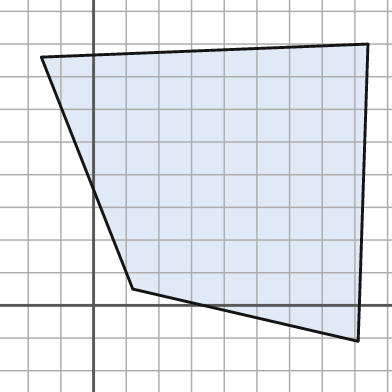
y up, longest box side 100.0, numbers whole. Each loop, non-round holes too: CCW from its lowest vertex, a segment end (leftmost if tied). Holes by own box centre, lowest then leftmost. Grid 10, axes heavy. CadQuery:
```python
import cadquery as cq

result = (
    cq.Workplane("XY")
    .moveTo(81.0, -11.0)
    .lineTo(84.0, 80.0)
    .lineTo(-16.0, 76.0)
    .lineTo(12.0, 5.0)
    .close()
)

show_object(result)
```